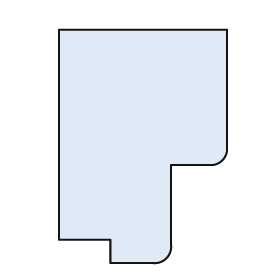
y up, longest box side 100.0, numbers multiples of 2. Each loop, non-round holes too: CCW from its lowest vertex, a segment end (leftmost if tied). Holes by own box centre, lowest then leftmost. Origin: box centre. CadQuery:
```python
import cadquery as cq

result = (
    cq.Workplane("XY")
    .moveTo(-14.0, -50.0)
    .lineTo(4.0, -50.0)
    .threePointArc((10.0, -48.0), (12.0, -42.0))
    .lineTo(12.0, -8.0)
    .lineTo(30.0, -8.0)
    .threePointArc((34.0, -6.0), (36.0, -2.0))
    .lineTo(36.0, 50.0)
    .lineTo(-36.0, 50.0)
    .lineTo(-36.0, -40.0)
    .lineTo(-14.0, -40.0)
    .close()
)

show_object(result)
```